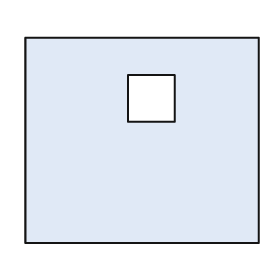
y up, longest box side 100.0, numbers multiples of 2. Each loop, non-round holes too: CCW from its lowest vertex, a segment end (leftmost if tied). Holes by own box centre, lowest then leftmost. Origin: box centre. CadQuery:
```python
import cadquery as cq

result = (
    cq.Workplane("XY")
    .moveTo(-50.0, -44.0)
    .lineTo(50.0, -44.0)
    .lineTo(50.0, 44.0)
    .lineTo(-50.0, 44.0)
    .close()
    .moveTo(-6.0, 8.0)
    .lineTo(14.0, 8.0)
    .lineTo(14.0, 28.0)
    .lineTo(-6.0, 28.0)
    .close()
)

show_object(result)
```